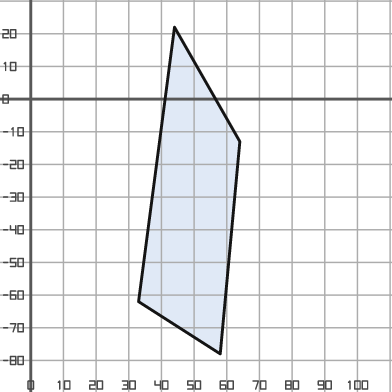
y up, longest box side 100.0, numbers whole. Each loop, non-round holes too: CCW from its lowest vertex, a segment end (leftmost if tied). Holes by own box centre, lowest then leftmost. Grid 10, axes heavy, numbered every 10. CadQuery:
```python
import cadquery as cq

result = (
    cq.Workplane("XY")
    .moveTo(58.0, -78.0)
    .lineTo(64.0, -13.0)
    .lineTo(44.0, 22.0)
    .lineTo(33.0, -62.0)
    .close()
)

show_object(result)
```